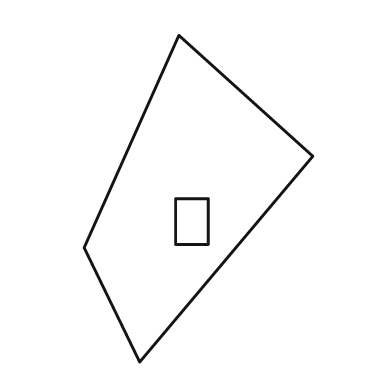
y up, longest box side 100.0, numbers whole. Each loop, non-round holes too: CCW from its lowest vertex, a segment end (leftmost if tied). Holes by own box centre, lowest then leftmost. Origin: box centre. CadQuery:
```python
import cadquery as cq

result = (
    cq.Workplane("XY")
    .moveTo(-18.0, -50.0)
    .lineTo(35.0, 13.0)
    .lineTo(-6.0, 50.0)
    .lineTo(-35.0, -15.0)
    .close()
    .moveTo(-7.0, -14.0)
    .lineTo(3.0, -14.0)
    .lineTo(3.0, 0.0)
    .lineTo(-7.0, 0.0)
    .close()
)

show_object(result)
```